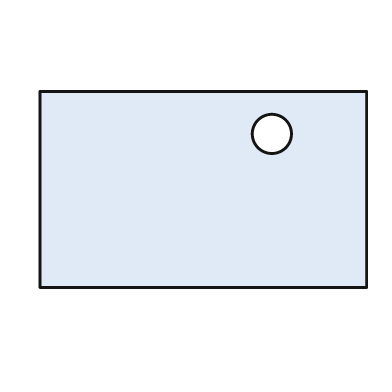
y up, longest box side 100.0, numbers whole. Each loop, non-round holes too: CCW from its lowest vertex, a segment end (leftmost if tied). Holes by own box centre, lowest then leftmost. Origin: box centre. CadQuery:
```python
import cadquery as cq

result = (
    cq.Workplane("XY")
    .moveTo(-50.0, -30.0)
    .lineTo(50.0, -30.0)
    .lineTo(50.0, 30.0)
    .lineTo(-50.0, 30.0)
    .close()
    .moveTo(21.0, 17.0)
    .circle(6.0)
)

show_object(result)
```